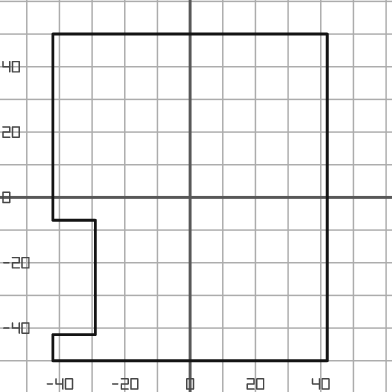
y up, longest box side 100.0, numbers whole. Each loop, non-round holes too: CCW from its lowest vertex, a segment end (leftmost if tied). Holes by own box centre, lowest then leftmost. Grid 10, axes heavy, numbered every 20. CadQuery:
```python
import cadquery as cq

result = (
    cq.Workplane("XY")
    .moveTo(-42.0, -50.0)
    .lineTo(42.0, -50.0)
    .lineTo(42.0, 50.0)
    .lineTo(-42.0, 50.0)
    .lineTo(-42.0, -7.0)
    .lineTo(-29.0, -7.0)
    .lineTo(-29.0, -42.0)
    .lineTo(-42.0, -42.0)
    .close()
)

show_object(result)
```